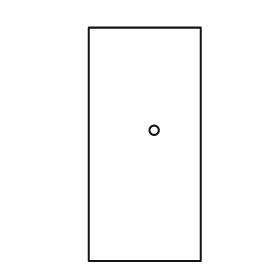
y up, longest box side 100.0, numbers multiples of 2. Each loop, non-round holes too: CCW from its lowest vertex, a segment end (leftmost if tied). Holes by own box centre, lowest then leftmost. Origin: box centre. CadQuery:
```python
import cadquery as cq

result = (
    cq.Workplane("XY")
    .moveTo(-24.0, -50.0)
    .lineTo(24.0, -50.0)
    .lineTo(24.0, 50.0)
    .lineTo(-24.0, 50.0)
    .close()
    .moveTo(4.0, 6.0)
    .circle(2.0)
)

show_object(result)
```